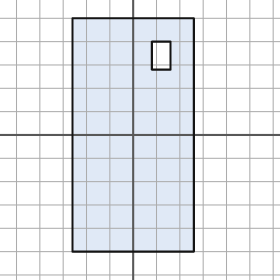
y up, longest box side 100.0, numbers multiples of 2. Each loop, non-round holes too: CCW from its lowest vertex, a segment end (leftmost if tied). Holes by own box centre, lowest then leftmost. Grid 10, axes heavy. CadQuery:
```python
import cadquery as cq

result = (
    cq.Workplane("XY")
    .moveTo(-26.0, -50.0)
    .lineTo(26.0, -50.0)
    .lineTo(26.0, 50.0)
    .lineTo(-26.0, 50.0)
    .close()
    .moveTo(8.0, 28.0)
    .lineTo(16.0, 28.0)
    .lineTo(16.0, 40.0)
    .lineTo(8.0, 40.0)
    .close()
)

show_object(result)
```